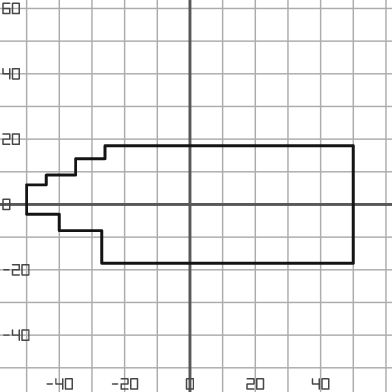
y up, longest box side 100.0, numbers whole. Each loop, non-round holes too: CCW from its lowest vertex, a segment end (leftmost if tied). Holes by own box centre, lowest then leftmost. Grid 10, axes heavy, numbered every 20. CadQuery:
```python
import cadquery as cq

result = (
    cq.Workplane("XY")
    .moveTo(-27.0, -18.0)
    .lineTo(50.0, -18.0)
    .lineTo(50.0, 18.0)
    .lineTo(-26.0, 18.0)
    .lineTo(-26.0, 14.0)
    .lineTo(-35.0, 14.0)
    .lineTo(-35.0, 9.0)
    .lineTo(-44.0, 9.0)
    .lineTo(-44.0, 6.0)
    .lineTo(-50.0, 6.0)
    .lineTo(-50.0, -3.0)
    .lineTo(-40.0, -3.0)
    .lineTo(-40.0, -8.0)
    .lineTo(-27.0, -8.0)
    .close()
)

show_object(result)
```